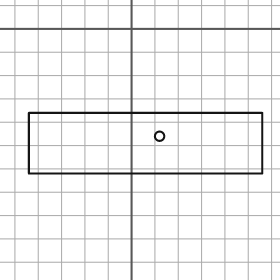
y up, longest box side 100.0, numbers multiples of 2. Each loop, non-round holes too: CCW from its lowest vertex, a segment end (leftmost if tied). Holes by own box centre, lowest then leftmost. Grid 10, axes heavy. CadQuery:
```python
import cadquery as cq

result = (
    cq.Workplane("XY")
    .moveTo(-44.0, -62.0)
    .lineTo(56.0, -62.0)
    .lineTo(56.0, -36.0)
    .lineTo(-44.0, -36.0)
    .close()
    .moveTo(12.0, -46.0)
    .circle(2.0)
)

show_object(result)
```